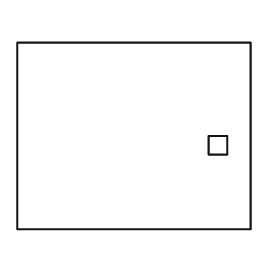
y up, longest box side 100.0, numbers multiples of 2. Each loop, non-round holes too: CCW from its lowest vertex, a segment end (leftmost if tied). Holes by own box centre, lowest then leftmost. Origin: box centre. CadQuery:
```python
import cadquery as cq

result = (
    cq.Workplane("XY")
    .moveTo(-50.0, -40.0)
    .lineTo(50.0, -40.0)
    .lineTo(50.0, 40.0)
    .lineTo(-50.0, 40.0)
    .close()
    .moveTo(32.0, -8.0)
    .lineTo(40.0, -8.0)
    .lineTo(40.0, 0.0)
    .lineTo(32.0, 0.0)
    .close()
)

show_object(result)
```